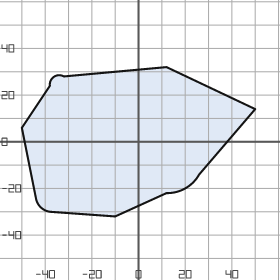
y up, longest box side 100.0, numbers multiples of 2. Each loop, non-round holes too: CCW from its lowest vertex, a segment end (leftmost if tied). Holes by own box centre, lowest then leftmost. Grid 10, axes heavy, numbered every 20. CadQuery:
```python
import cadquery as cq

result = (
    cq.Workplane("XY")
    .moveTo(-10.0, -32.0)
    .lineTo(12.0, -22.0)
    .threePointArc((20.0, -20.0), (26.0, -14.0))
    .lineTo(50.0, 14.0)
    .lineTo(12.0, 32.0)
    .lineTo(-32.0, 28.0)
    .threePointArc((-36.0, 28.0), (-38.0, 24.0))
    .lineTo(-50.0, 6.0)
    .lineTo(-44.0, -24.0)
    .threePointArc((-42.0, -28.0), (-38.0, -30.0))
    .close()
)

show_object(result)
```